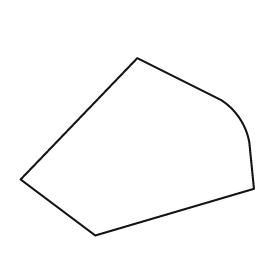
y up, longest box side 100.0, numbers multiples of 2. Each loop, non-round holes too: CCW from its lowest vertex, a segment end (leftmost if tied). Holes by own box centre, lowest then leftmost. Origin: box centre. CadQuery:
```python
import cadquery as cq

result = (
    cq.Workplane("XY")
    .moveTo(-18.0, -38.0)
    .lineTo(50.0, -18.0)
    .lineTo(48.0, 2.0)
    .threePointArc((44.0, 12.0), (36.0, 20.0))
    .lineTo(0.0, 38.0)
    .lineTo(-50.0, -14.0)
    .close()
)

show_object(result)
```